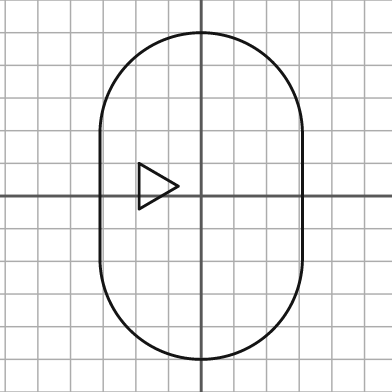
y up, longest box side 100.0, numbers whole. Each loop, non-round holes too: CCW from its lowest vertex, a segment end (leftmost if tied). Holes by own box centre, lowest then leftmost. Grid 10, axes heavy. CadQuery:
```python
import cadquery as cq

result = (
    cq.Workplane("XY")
    .moveTo(-31.0, -19.0)
    .threePointArc((0.0, -50.0), (31.0, -19.0))
    .lineTo(31.0, 19.0)
    .threePointArc((0.0, 50.0), (-31.0, 19.0))
    .close()
    .moveTo(-19.0, -4.0)
    .lineTo(-7.0, 3.0)
    .lineTo(-19.0, 10.0)
    .close()
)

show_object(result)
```